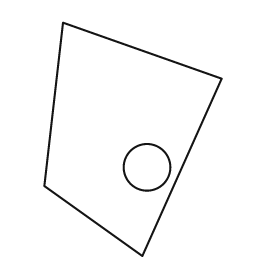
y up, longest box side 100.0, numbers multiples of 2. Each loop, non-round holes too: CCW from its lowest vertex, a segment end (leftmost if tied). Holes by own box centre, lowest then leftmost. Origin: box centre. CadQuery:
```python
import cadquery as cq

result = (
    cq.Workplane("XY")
    .moveTo(4.0, -50.0)
    .lineTo(38.0, 26.0)
    .lineTo(-30.0, 50.0)
    .lineTo(-38.0, -20.0)
    .close()
    .moveTo(6.0, -12.0)
    .circle(10.0)
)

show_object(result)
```